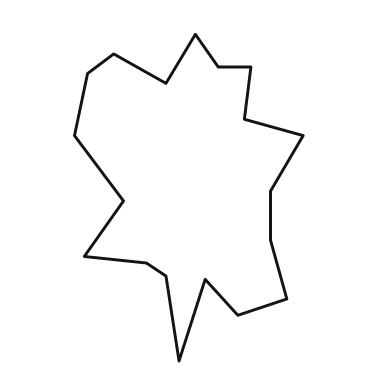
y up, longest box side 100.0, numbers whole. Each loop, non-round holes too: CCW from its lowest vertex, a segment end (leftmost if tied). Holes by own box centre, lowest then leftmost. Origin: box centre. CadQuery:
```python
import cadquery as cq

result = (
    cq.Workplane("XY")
    .moveTo(-3.0, -50.0)
    .lineTo(5.0, -25.0)
    .lineTo(15.0, -36.0)
    .lineTo(30.0, -31.0)
    .lineTo(25.0, -13.0)
    .lineTo(25.0, 2.0)
    .lineTo(35.0, 19.0)
    .lineTo(17.0, 24.0)
    .lineTo(19.0, 40.0)
    .lineTo(9.0, 40.0)
    .lineTo(2.0, 50.0)
    .lineTo(-7.0, 35.0)
    .lineTo(-23.0, 44.0)
    .lineTo(-31.0, 38.0)
    .lineTo(-35.0, 19.0)
    .lineTo(-20.0, -1.0)
    .lineTo(-32.0, -18.0)
    .lineTo(-13.0, -20.0)
    .lineTo(-7.0, -24.0)
    .close()
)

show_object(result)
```